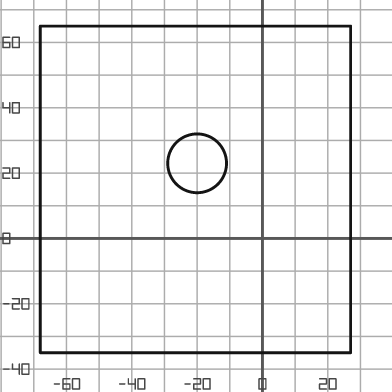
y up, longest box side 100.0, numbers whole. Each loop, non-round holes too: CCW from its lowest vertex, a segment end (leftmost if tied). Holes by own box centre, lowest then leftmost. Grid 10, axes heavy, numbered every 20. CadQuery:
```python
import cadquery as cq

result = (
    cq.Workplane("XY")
    .moveTo(-68.0, -35.0)
    .lineTo(27.0, -35.0)
    .lineTo(27.0, 65.0)
    .lineTo(-68.0, 65.0)
    .close()
    .moveTo(-20.0, 23.0)
    .circle(9.0)
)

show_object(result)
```